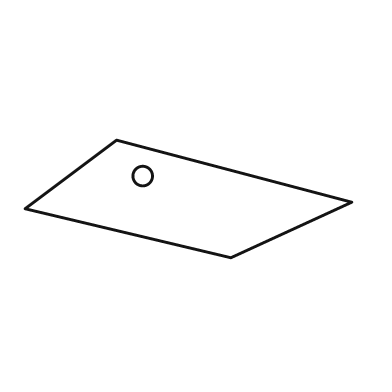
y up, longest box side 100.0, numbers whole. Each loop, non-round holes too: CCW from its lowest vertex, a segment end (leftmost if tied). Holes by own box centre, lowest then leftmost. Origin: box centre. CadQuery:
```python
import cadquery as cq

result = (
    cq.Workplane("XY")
    .moveTo(13.0, -18.0)
    .lineTo(50.0, -1.0)
    .lineTo(-22.0, 18.0)
    .lineTo(-50.0, -3.0)
    .close()
    .moveTo(-14.0, 7.0)
    .circle(3.0)
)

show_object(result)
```